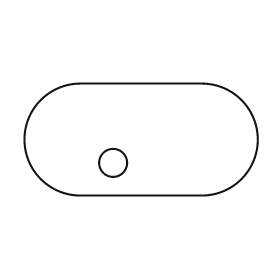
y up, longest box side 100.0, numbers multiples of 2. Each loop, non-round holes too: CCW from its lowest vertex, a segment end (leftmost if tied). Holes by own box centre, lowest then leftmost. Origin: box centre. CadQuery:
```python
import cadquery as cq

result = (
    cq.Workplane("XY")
    .moveTo(-26.0, -24.0)
    .lineTo(26.0, -24.0)
    .threePointArc((50.0, 0.0), (26.0, 24.0))
    .lineTo(-26.0, 24.0)
    .threePointArc((-50.0, 0.0), (-26.0, -24.0))
    .close()
    .moveTo(-12.0, -10.0)
    .circle(6.0)
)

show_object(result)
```